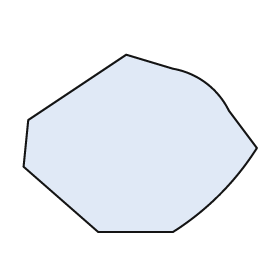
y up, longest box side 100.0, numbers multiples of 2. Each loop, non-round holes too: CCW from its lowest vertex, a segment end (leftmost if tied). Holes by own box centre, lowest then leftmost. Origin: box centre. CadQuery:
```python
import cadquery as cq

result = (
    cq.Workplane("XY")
    .moveTo(-18.0, -38.0)
    .lineTo(14.0, -38.0)
    .threePointArc((34.0, -22.0), (50.0, -2.0))
    .lineTo(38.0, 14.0)
    .threePointArc((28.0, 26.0), (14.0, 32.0))
    .lineTo(-6.0, 38.0)
    .lineTo(-48.0, 10.0)
    .lineTo(-50.0, -10.0)
    .close()
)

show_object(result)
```